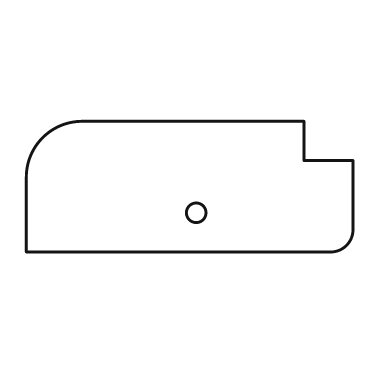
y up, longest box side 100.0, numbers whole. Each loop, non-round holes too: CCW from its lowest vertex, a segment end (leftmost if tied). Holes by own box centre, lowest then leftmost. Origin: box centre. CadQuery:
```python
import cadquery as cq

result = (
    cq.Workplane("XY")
    .moveTo(-50.0, -20.0)
    .lineTo(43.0, -20.0)
    .threePointArc((48.0, -18.0), (50.0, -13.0))
    .lineTo(50.0, 8.0)
    .lineTo(35.0, 8.0)
    .lineTo(35.0, 20.0)
    .lineTo(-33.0, 20.0)
    .threePointArc((-45.0, 15.0), (-50.0, 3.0))
    .close()
    .moveTo(2.0, -8.0)
    .circle(3.0)
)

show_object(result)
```